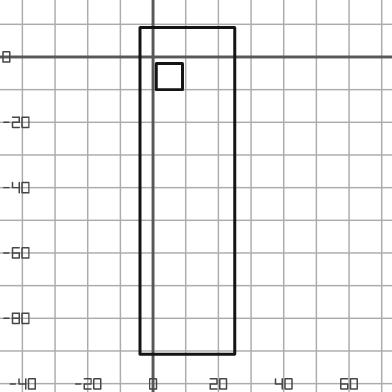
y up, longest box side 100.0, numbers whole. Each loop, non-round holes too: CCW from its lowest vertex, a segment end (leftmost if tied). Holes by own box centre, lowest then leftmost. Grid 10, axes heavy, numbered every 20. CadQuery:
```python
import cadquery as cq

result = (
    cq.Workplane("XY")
    .moveTo(-4.0, -91.0)
    .lineTo(25.0, -91.0)
    .lineTo(25.0, 9.0)
    .lineTo(-4.0, 9.0)
    .close()
    .moveTo(1.0, -10.0)
    .lineTo(9.0, -10.0)
    .lineTo(9.0, -2.0)
    .lineTo(1.0, -2.0)
    .close()
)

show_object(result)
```